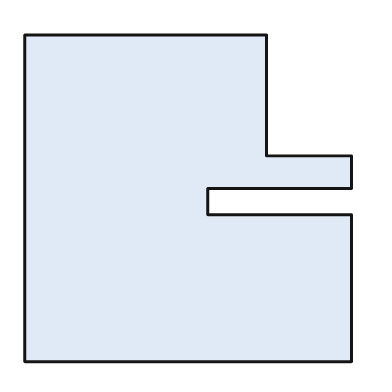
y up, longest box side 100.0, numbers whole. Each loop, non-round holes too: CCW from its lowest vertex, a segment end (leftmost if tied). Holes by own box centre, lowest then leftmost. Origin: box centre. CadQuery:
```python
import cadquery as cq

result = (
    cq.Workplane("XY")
    .moveTo(-50.0, -50.0)
    .lineTo(50.0, -50.0)
    .lineTo(50.0, -5.0)
    .lineTo(6.0, -5.0)
    .lineTo(6.0, 3.0)
    .lineTo(50.0, 3.0)
    .lineTo(50.0, 13.0)
    .lineTo(24.0, 13.0)
    .lineTo(24.0, 50.0)
    .lineTo(-50.0, 50.0)
    .close()
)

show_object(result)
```